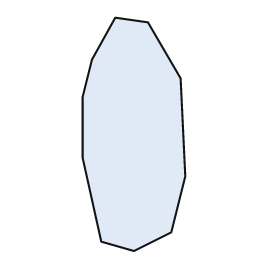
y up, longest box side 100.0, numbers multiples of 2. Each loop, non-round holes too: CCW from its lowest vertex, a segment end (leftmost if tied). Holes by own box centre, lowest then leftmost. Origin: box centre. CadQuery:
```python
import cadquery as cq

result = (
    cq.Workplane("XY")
    .moveTo(0.0, -50.0)
    .lineTo(16.0, -42.0)
    .lineTo(22.0, -18.0)
    .lineTo(20.0, 24.0)
    .lineTo(6.0, 48.0)
    .lineTo(-8.0, 50.0)
    .lineTo(-18.0, 32.0)
    .lineTo(-22.0, 16.0)
    .lineTo(-22.0, -10.0)
    .lineTo(-14.0, -46.0)
    .close()
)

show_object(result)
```